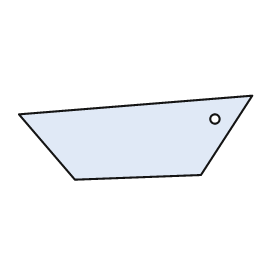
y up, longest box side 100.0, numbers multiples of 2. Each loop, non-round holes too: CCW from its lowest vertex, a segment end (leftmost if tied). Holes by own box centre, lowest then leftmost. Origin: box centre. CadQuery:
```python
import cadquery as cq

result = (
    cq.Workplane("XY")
    .moveTo(-26.0, -18.0)
    .lineTo(28.0, -16.0)
    .lineTo(50.0, 18.0)
    .lineTo(-50.0, 10.0)
    .close()
    .moveTo(34.0, 8.0)
    .circle(2.0)
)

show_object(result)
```